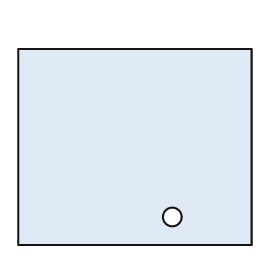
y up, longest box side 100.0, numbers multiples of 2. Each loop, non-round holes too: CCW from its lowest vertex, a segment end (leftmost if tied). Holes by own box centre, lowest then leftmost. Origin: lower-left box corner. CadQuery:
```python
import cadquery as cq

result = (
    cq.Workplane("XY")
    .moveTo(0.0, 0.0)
    .lineTo(100.0, 0.0)
    .lineTo(100.0, 84.0)
    .lineTo(0.0, 84.0)
    .close()
    .moveTo(66.0, 12.0)
    .circle(4.0)
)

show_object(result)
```